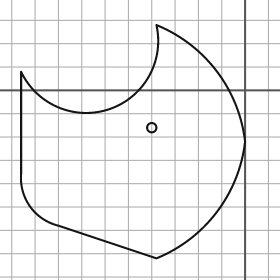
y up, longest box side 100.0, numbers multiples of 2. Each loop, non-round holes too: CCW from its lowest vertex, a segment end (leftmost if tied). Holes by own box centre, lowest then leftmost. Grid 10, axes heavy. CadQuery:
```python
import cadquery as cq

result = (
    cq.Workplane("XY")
    .moveTo(-38.0, -72.0)
    .threePointArc((-12.0, -52.0), (0.0, -22.0))
    .threePointArc((-12.0, 8.0), (-38.0, 28.0))
    .threePointArc((-58.0, -8.0), (-96.0, 8.0))
    .lineTo(-96.0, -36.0)
    .threePointArc((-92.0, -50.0), (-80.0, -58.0))
    .close()
    .moveTo(-40.0, -16.0)
    .circle(2.0)
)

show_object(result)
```